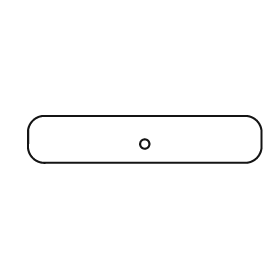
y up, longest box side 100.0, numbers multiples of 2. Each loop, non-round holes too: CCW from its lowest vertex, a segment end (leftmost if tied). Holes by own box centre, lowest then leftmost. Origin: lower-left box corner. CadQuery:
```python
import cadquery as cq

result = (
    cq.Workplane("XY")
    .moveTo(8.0, 0.0)
    .lineTo(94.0, 0.0)
    .threePointArc((98.0, 2.0), (100.0, 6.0))
    .lineTo(100.0, 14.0)
    .threePointArc((98.0, 18.0), (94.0, 20.0))
    .lineTo(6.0, 20.0)
    .threePointArc((2.0, 18.0), (0.0, 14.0))
    .lineTo(0.0, 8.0)
    .threePointArc((2.0, 2.0), (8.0, 0.0))
    .close()
    .moveTo(50.0, 8.0)
    .circle(2.0)
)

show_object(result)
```